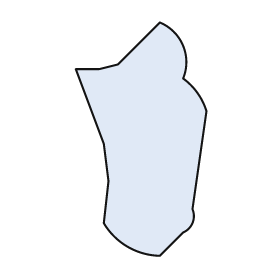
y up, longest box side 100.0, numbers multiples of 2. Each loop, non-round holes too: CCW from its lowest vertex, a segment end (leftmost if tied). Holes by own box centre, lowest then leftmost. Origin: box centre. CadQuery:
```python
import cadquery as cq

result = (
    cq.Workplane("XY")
    .moveTo(8.0, -50.0)
    .lineTo(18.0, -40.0)
    .threePointArc((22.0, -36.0), (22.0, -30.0))
    .lineTo(28.0, 12.0)
    .threePointArc((24.0, 20.0), (18.0, 26.0))
    .threePointArc((18.0, 40.0), (8.0, 50.0))
    .lineTo(-10.0, 32.0)
    .lineTo(-18.0, 30.0)
    .lineTo(-28.0, 30.0)
    .lineTo(-16.0, -2.0)
    .lineTo(-14.0, -18.0)
    .lineTo(-16.0, -36.0)
    .threePointArc((-6.0, -46.0), (8.0, -50.0))
    .close()
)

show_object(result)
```